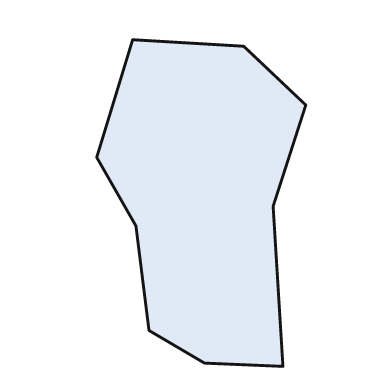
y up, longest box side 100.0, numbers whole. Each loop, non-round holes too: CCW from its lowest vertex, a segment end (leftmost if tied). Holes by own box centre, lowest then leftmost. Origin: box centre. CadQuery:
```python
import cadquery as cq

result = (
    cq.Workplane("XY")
    .moveTo(25.0, -50.0)
    .lineTo(22.0, -1.0)
    .lineTo(32.0, 30.0)
    .lineTo(13.0, 48.0)
    .lineTo(-21.0, 50.0)
    .lineTo(-32.0, 14.0)
    .lineTo(-20.0, -7.0)
    .lineTo(-16.0, -39.0)
    .lineTo(1.0, -49.0)
    .close()
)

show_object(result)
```